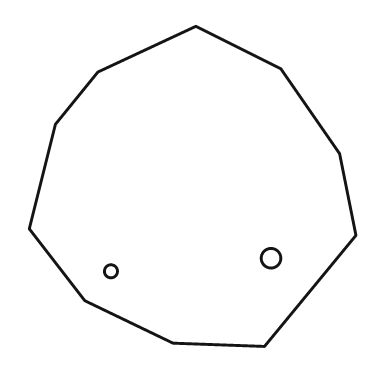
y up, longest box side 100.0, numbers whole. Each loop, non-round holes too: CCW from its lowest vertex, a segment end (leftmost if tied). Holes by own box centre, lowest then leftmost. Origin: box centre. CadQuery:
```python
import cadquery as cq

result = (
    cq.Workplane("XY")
    .moveTo(22.0, -49.0)
    .lineTo(50.0, -15.0)
    .lineTo(45.0, 10.0)
    .lineTo(27.0, 36.0)
    .lineTo(1.0, 49.0)
    .lineTo(-29.0, 35.0)
    .lineTo(-42.0, 19.0)
    .lineTo(-50.0, -13.0)
    .lineTo(-33.0, -35.0)
    .lineTo(-6.0, -48.0)
    .close()
    .moveTo(-25.0, -26.0)
    .circle(2.0)
    .moveTo(24.0, -22.0)
    .circle(3.0)
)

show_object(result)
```